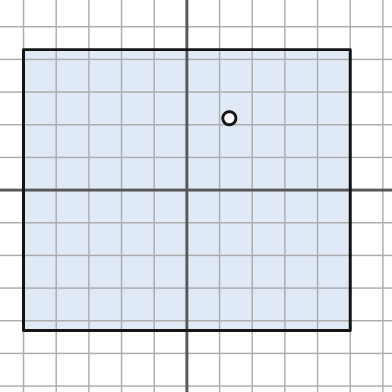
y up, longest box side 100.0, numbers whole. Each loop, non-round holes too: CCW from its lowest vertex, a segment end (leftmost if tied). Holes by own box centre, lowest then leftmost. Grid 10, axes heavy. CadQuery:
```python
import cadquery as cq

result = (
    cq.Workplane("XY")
    .moveTo(-50.0, -43.0)
    .lineTo(50.0, -43.0)
    .lineTo(50.0, 43.0)
    .lineTo(-50.0, 43.0)
    .close()
    .moveTo(13.0, 22.0)
    .circle(2.0)
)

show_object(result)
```